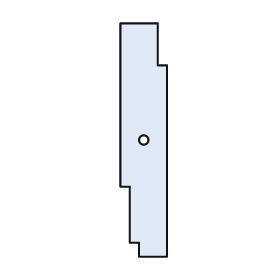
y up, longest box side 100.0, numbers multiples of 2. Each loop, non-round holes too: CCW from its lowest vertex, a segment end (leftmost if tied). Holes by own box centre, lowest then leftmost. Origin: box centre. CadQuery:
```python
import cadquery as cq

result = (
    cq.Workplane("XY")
    .moveTo(-2.0, -50.0)
    .lineTo(10.0, -50.0)
    .lineTo(10.0, 32.0)
    .lineTo(6.0, 32.0)
    .lineTo(6.0, 50.0)
    .lineTo(-10.0, 50.0)
    .lineTo(-10.0, -20.0)
    .lineTo(-6.0, -20.0)
    .lineTo(-6.0, -44.0)
    .lineTo(-2.0, -44.0)
    .close()
    .moveTo(0.0, 0.0)
    .circle(2.0)
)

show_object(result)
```